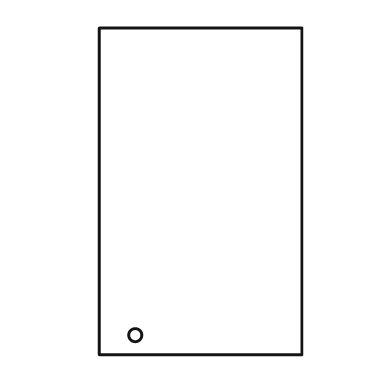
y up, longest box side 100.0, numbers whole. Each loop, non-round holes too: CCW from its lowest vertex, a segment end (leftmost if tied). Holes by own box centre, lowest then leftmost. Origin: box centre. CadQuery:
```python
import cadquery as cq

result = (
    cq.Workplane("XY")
    .moveTo(-31.0, -50.0)
    .lineTo(31.0, -50.0)
    .lineTo(31.0, 50.0)
    .lineTo(-31.0, 50.0)
    .close()
    .moveTo(-20.0, -44.0)
    .circle(2.0)
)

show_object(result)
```